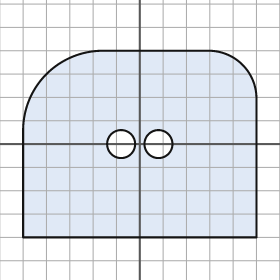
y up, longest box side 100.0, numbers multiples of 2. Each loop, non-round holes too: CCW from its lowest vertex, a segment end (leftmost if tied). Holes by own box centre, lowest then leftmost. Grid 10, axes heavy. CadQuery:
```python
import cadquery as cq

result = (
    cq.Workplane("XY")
    .moveTo(-50.0, -40.0)
    .lineTo(50.0, -40.0)
    .lineTo(50.0, 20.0)
    .threePointArc((44.0, 34.0), (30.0, 40.0))
    .lineTo(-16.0, 40.0)
    .threePointArc((-40.0, 30.0), (-50.0, 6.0))
    .close()
    .moveTo(-8.0, 0.0)
    .circle(6.0)
    .moveTo(8.0, 0.0)
    .circle(6.0)
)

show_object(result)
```